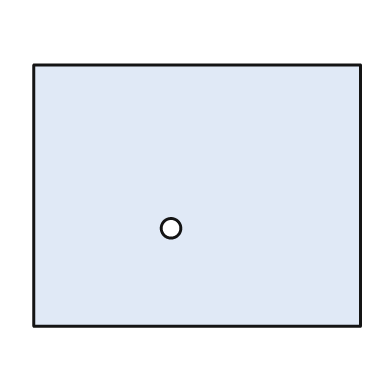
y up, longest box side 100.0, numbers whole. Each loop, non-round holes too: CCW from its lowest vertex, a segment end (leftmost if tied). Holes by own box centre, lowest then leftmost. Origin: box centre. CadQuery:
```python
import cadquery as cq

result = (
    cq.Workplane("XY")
    .moveTo(-50.0, -40.0)
    .lineTo(50.0, -40.0)
    .lineTo(50.0, 40.0)
    .lineTo(-50.0, 40.0)
    .close()
    .moveTo(-8.0, -10.0)
    .circle(3.0)
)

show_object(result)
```